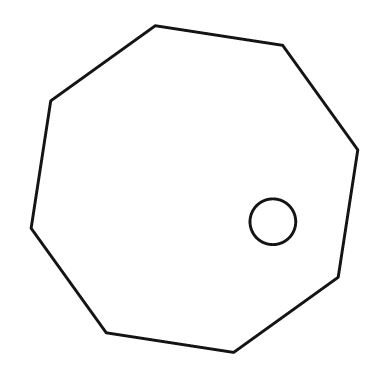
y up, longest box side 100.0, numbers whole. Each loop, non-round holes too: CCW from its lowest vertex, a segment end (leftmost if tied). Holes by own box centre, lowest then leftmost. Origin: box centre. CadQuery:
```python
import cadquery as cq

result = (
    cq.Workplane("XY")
    .moveTo(12.0, -50.0)
    .lineTo(44.0, -27.0)
    .lineTo(50.0, 12.0)
    .lineTo(27.0, 44.0)
    .lineTo(-12.0, 50.0)
    .lineTo(-44.0, 27.0)
    .lineTo(-50.0, -12.0)
    .lineTo(-27.0, -44.0)
    .close()
    .moveTo(24.0, -10.0)
    .circle(7.0)
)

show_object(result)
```